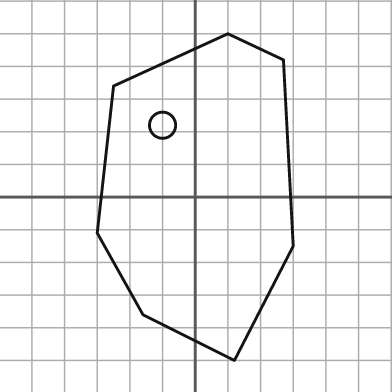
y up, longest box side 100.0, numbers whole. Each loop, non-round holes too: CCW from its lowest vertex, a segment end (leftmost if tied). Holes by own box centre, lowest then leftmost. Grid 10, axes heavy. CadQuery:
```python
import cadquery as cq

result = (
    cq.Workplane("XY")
    .moveTo(12.0, -50.0)
    .lineTo(30.0, -15.0)
    .lineTo(27.0, 42.0)
    .lineTo(10.0, 50.0)
    .lineTo(-25.0, 34.0)
    .lineTo(-30.0, -11.0)
    .lineTo(-16.0, -36.0)
    .close()
    .moveTo(-10.0, 22.0)
    .circle(4.0)
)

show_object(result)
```